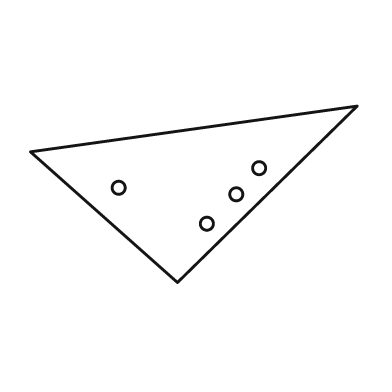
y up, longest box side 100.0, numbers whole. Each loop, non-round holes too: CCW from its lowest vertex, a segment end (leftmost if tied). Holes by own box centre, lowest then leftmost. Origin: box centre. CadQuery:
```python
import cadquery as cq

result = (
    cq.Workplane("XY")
    .moveTo(-5.0, -27.0)
    .lineTo(50.0, 27.0)
    .lineTo(-50.0, 13.0)
    .close()
    .moveTo(4.0, -9.0)
    .circle(2.0)
    .moveTo(13.0, 0.0)
    .circle(2.0)
    .moveTo(-23.0, 2.0)
    .circle(2.0)
    .moveTo(20.0, 8.0)
    .circle(2.0)
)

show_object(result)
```